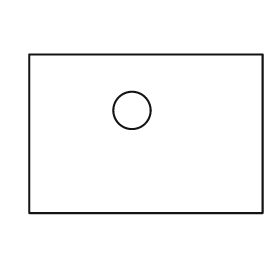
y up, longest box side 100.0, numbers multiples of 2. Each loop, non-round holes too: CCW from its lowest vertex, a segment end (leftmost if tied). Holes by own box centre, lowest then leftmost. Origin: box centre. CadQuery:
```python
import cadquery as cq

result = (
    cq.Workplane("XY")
    .moveTo(-50.0, -34.0)
    .lineTo(50.0, -34.0)
    .lineTo(50.0, 34.0)
    .lineTo(-50.0, 34.0)
    .close()
    .moveTo(-6.0, 10.0)
    .circle(8.0)
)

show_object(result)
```